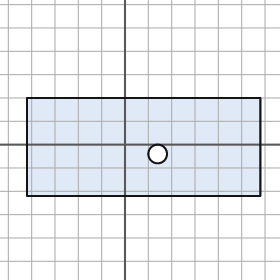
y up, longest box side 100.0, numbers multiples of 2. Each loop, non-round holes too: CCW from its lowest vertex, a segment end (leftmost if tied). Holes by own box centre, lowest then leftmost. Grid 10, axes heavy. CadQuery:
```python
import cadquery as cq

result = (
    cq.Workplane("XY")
    .moveTo(-42.0, -22.0)
    .lineTo(58.0, -22.0)
    .lineTo(58.0, 20.0)
    .lineTo(-42.0, 20.0)
    .close()
    .moveTo(14.0, -4.0)
    .circle(4.0)
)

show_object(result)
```